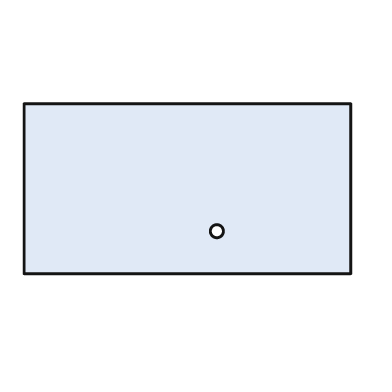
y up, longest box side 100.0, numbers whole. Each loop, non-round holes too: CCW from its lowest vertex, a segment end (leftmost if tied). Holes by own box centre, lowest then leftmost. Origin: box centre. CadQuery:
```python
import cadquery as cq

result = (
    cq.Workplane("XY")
    .moveTo(-50.0, -26.0)
    .lineTo(50.0, -26.0)
    .lineTo(50.0, 26.0)
    .lineTo(-50.0, 26.0)
    .close()
    .moveTo(9.0, -13.0)
    .circle(2.0)
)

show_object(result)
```